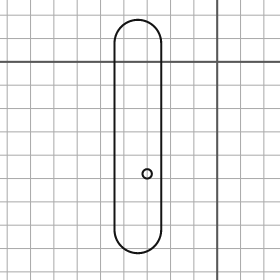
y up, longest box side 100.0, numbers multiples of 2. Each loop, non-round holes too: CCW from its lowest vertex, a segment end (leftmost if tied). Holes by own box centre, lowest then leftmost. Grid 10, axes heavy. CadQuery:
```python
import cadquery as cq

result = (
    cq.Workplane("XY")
    .moveTo(-44.0, -72.0)
    .threePointArc((-34.0, -82.0), (-24.0, -72.0))
    .lineTo(-24.0, 8.0)
    .threePointArc((-34.0, 18.0), (-44.0, 8.0))
    .close()
    .moveTo(-30.0, -48.0)
    .circle(2.0)
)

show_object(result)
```